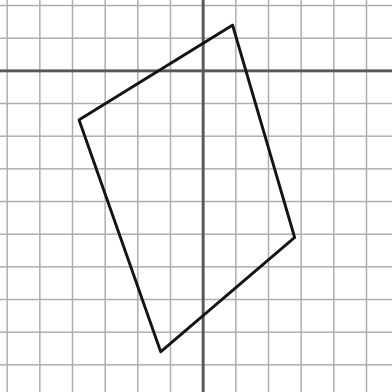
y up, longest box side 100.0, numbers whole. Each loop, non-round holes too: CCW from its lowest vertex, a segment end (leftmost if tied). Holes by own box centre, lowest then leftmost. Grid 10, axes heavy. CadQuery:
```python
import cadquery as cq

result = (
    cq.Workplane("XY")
    .moveTo(-13.0, -86.0)
    .lineTo(28.0, -51.0)
    .lineTo(9.0, 14.0)
    .lineTo(-38.0, -15.0)
    .close()
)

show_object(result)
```